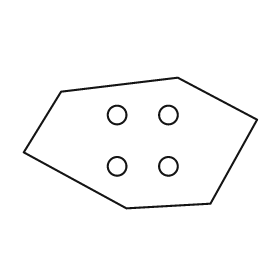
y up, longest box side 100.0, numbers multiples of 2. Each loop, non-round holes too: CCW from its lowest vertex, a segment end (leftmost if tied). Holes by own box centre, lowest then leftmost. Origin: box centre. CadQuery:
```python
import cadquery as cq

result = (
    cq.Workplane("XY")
    .moveTo(-6.0, -28.0)
    .lineTo(30.0, -26.0)
    .lineTo(50.0, 10.0)
    .lineTo(16.0, 28.0)
    .lineTo(-34.0, 22.0)
    .lineTo(-50.0, -4.0)
    .close()
    .moveTo(-10.0, -10.0)
    .circle(4.0)
    .moveTo(12.0, -10.0)
    .circle(4.0)
    .moveTo(-10.0, 12.0)
    .circle(4.0)
    .moveTo(12.0, 12.0)
    .circle(4.0)
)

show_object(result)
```